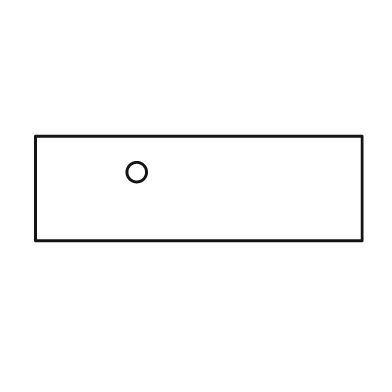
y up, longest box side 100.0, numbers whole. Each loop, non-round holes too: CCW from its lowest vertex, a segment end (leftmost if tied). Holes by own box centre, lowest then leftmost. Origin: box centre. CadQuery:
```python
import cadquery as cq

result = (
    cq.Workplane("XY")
    .moveTo(-50.0, -16.0)
    .lineTo(50.0, -16.0)
    .lineTo(50.0, 16.0)
    .lineTo(-50.0, 16.0)
    .close()
    .moveTo(-19.0, 5.0)
    .circle(3.0)
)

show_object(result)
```